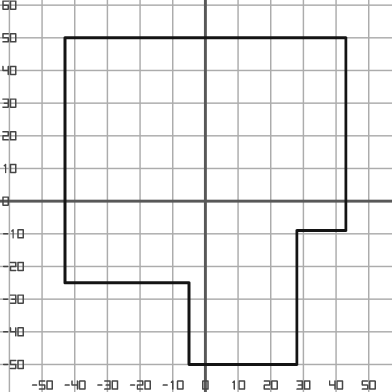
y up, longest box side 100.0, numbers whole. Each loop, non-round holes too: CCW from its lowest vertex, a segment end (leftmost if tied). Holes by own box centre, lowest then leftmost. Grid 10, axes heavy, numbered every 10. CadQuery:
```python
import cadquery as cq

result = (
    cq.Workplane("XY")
    .moveTo(-5.0, -50.0)
    .lineTo(28.0, -50.0)
    .lineTo(28.0, -9.0)
    .lineTo(43.0, -9.0)
    .lineTo(43.0, 50.0)
    .lineTo(-43.0, 50.0)
    .lineTo(-43.0, -25.0)
    .lineTo(-5.0, -25.0)
    .close()
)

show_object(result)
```